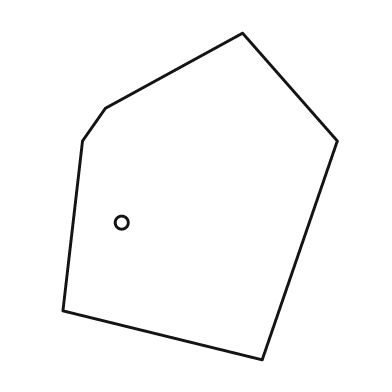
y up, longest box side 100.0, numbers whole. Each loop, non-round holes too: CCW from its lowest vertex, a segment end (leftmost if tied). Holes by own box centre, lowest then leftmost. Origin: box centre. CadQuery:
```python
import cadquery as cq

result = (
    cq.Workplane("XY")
    .moveTo(19.0, -50.0)
    .lineTo(42.0, 17.0)
    .lineTo(13.0, 50.0)
    .lineTo(-29.0, 27.0)
    .lineTo(-36.0, 17.0)
    .lineTo(-42.0, -35.0)
    .close()
    .moveTo(-24.0, -8.0)
    .circle(2.0)
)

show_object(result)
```